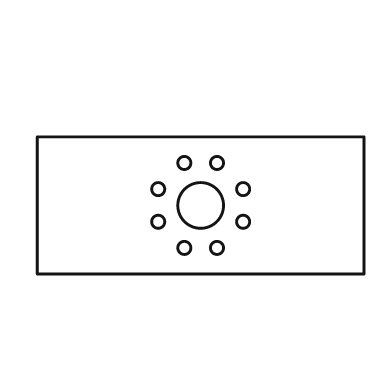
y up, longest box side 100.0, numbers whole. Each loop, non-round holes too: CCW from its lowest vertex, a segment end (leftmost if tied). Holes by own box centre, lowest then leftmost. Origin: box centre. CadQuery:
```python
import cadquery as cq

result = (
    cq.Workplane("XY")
    .moveTo(-50.0, -21.0)
    .lineTo(50.0, -21.0)
    .lineTo(50.0, 21.0)
    .lineTo(-50.0, 21.0)
    .close()
    .moveTo(-5.0, -13.0)
    .circle(2.0)
    .moveTo(5.0, -13.0)
    .circle(2.0)
    .moveTo(-13.0, -5.0)
    .circle(2.0)
    .moveTo(13.0, -5.0)
    .circle(2.0)
    .moveTo(0.0, 0.0)
    .circle(7.0)
    .moveTo(-13.0, 5.0)
    .circle(2.0)
    .moveTo(13.0, 5.0)
    .circle(2.0)
    .moveTo(-5.0, 13.0)
    .circle(2.0)
    .moveTo(5.0, 13.0)
    .circle(2.0)
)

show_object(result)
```